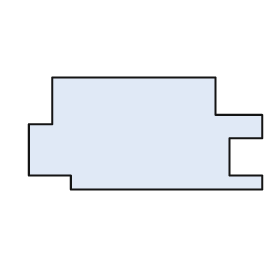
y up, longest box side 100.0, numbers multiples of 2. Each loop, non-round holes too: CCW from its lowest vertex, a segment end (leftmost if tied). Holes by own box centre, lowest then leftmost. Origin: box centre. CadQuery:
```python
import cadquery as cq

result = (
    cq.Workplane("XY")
    .moveTo(-32.0, -24.0)
    .lineTo(50.0, -24.0)
    .lineTo(50.0, -18.0)
    .lineTo(36.0, -18.0)
    .lineTo(36.0, -2.0)
    .lineTo(50.0, -2.0)
    .lineTo(50.0, 8.0)
    .lineTo(30.0, 8.0)
    .lineTo(30.0, 24.0)
    .lineTo(-40.0, 24.0)
    .lineTo(-40.0, 4.0)
    .lineTo(-50.0, 4.0)
    .lineTo(-50.0, -18.0)
    .lineTo(-32.0, -18.0)
    .close()
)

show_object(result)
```